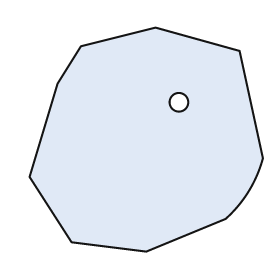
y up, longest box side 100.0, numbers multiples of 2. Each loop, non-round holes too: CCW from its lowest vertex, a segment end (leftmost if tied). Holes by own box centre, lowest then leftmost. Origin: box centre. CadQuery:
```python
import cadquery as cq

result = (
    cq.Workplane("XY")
    .moveTo(0.0, -48.0)
    .lineTo(34.0, -34.0)
    .threePointArc((44.0, -22.0), (50.0, -8.0))
    .lineTo(40.0, 38.0)
    .lineTo(4.0, 48.0)
    .lineTo(-28.0, 40.0)
    .lineTo(-38.0, 24.0)
    .lineTo(-50.0, -16.0)
    .lineTo(-32.0, -44.0)
    .close()
    .moveTo(14.0, 16.0)
    .circle(4.0)
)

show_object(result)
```